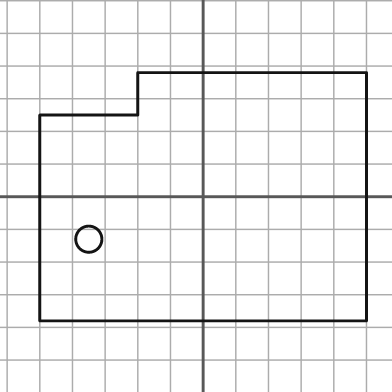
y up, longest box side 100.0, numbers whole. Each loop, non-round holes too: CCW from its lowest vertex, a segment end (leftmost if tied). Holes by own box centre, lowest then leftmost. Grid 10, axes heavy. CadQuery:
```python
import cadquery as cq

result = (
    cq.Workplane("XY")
    .moveTo(-50.0, -38.0)
    .lineTo(50.0, -38.0)
    .lineTo(50.0, 38.0)
    .lineTo(-20.0, 38.0)
    .lineTo(-20.0, 25.0)
    .lineTo(-50.0, 25.0)
    .close()
    .moveTo(-35.0, -13.0)
    .circle(4.0)
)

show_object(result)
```